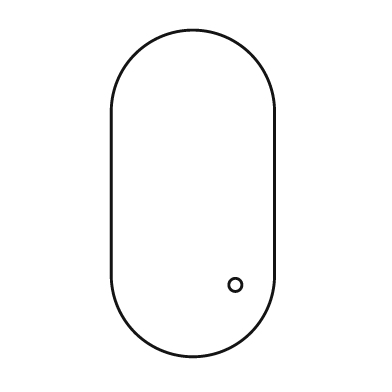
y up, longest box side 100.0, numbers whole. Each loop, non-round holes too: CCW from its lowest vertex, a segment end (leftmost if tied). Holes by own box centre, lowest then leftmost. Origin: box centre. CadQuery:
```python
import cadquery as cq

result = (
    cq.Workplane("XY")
    .moveTo(-25.0, -25.0)
    .threePointArc((0.0, -50.0), (25.0, -25.0))
    .lineTo(25.0, 25.0)
    .threePointArc((0.0, 50.0), (-25.0, 25.0))
    .close()
    .moveTo(13.0, -28.0)
    .circle(2.0)
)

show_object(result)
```